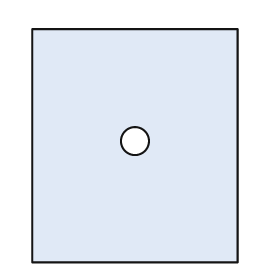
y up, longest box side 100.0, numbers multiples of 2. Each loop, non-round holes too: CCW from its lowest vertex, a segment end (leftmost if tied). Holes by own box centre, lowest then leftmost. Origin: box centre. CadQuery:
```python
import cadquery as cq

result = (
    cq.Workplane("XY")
    .moveTo(-44.0, -50.0)
    .lineTo(44.0, -50.0)
    .lineTo(44.0, 50.0)
    .lineTo(-44.0, 50.0)
    .close()
    .moveTo(0.0, 2.0)
    .circle(6.0)
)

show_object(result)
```